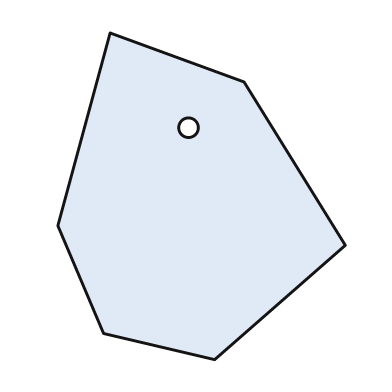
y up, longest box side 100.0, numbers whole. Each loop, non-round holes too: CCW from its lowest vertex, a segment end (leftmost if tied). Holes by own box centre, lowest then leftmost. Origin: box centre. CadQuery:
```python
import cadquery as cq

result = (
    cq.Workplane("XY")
    .moveTo(4.0, -50.0)
    .lineTo(44.0, -15.0)
    .lineTo(13.0, 35.0)
    .lineTo(-28.0, 50.0)
    .lineTo(-44.0, -9.0)
    .lineTo(-30.0, -42.0)
    .close()
    .moveTo(-4.0, 21.0)
    .circle(3.0)
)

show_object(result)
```